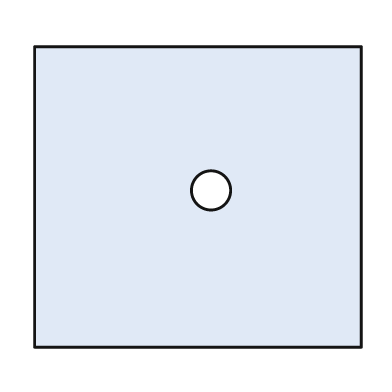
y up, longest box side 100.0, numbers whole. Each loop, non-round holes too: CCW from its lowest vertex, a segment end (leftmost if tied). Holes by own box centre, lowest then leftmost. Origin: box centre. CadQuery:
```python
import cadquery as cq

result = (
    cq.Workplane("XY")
    .moveTo(-50.0, -46.0)
    .lineTo(50.0, -46.0)
    .lineTo(50.0, 46.0)
    .lineTo(-50.0, 46.0)
    .close()
    .moveTo(4.0, 2.0)
    .circle(6.0)
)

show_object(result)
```